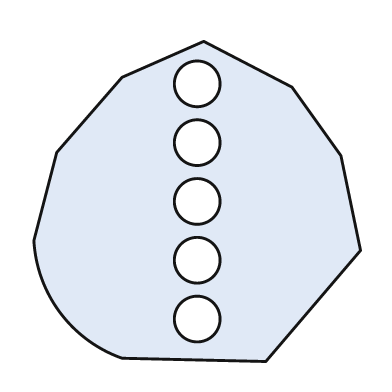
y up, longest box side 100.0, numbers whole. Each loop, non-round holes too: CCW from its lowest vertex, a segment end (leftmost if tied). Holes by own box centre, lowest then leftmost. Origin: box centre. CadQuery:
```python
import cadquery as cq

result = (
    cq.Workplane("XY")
    .moveTo(21.0, -49.0)
    .lineTo(50.0, -15.0)
    .lineTo(44.0, 14.0)
    .lineTo(29.0, 35.0)
    .lineTo(2.0, 49.0)
    .lineTo(-23.0, 38.0)
    .lineTo(-43.0, 15.0)
    .lineTo(-50.0, -12.0)
    .threePointArc((-42.0, -34.0), (-23.0, -48.0))
    .close()
    .moveTo(0.0, -36.0)
    .circle(7.0)
    .moveTo(0.0, -18.0)
    .circle(7.0)
    .moveTo(0.0, 0.0)
    .circle(7.0)
    .moveTo(0.0, 18.0)
    .circle(7.0)
    .moveTo(0.0, 36.0)
    .circle(7.0)
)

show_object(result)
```